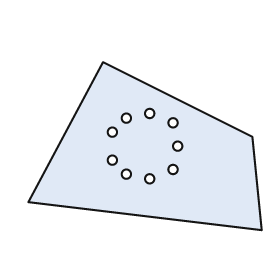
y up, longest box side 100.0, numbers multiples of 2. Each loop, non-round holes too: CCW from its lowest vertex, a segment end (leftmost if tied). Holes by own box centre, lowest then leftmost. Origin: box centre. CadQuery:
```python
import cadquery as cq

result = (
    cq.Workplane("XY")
    .moveTo(50.0, -36.0)
    .lineTo(46.0, 4.0)
    .lineTo(-18.0, 36.0)
    .lineTo(-50.0, -24.0)
    .close()
    .moveTo(2.0, -14.0)
    .circle(2.0)
    .moveTo(-8.0, -12.0)
    .circle(2.0)
    .moveTo(12.0, -10.0)
    .circle(2.0)
    .moveTo(-14.0, -6.0)
    .circle(2.0)
    .moveTo(14.0, 0.0)
    .circle(2.0)
    .moveTo(-14.0, 6.0)
    .circle(2.0)
    .moveTo(12.0, 10.0)
    .circle(2.0)
    .moveTo(-8.0, 12.0)
    .circle(2.0)
    .moveTo(2.0, 14.0)
    .circle(2.0)
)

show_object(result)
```